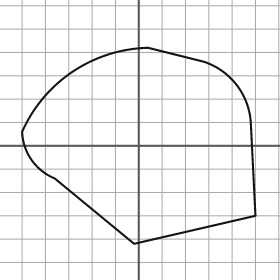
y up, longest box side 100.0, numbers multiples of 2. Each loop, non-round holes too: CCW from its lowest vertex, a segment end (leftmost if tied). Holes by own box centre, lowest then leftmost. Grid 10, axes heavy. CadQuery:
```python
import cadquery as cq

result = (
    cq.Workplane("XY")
    .moveTo(-2.0, -42.0)
    .lineTo(50.0, -30.0)
    .lineTo(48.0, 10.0)
    .threePointArc((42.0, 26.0), (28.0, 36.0))
    .lineTo(4.0, 42.0)
    .threePointArc((-28.0, 32.0), (-50.0, 6.0))
    .threePointArc((-46.0, -6.0), (-36.0, -14.0))
    .close()
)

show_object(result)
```